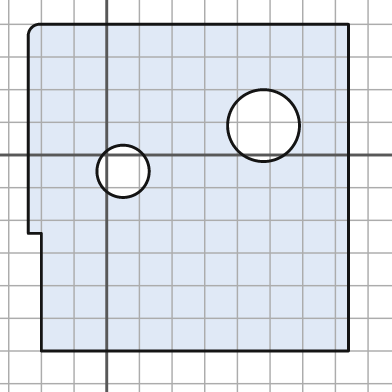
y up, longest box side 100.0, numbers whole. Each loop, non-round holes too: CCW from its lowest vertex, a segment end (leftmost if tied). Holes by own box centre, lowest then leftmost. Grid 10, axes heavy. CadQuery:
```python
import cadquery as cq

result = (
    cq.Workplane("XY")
    .moveTo(-20.0, -60.0)
    .lineTo(74.0, -60.0)
    .lineTo(74.0, 40.0)
    .lineTo(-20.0, 40.0)
    .threePointArc((-23.0, 39.0), (-24.0, 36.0))
    .lineTo(-24.0, -24.0)
    .lineTo(-20.0, -24.0)
    .close()
    .moveTo(5.0, -5.0)
    .circle(8.0)
    .moveTo(48.0, 9.0)
    .circle(11.0)
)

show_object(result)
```